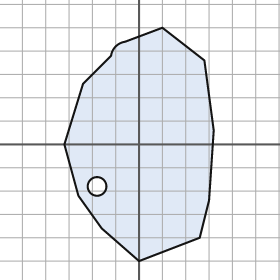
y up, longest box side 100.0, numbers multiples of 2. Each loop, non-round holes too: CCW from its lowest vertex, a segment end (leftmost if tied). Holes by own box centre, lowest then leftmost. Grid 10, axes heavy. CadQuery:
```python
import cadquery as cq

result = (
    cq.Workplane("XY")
    .moveTo(0.0, -50.0)
    .lineTo(26.0, -40.0)
    .lineTo(30.0, -24.0)
    .lineTo(32.0, 6.0)
    .lineTo(28.0, 36.0)
    .lineTo(10.0, 50.0)
    .lineTo(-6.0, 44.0)
    .threePointArc((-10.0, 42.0), (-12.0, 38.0))
    .lineTo(-24.0, 26.0)
    .lineTo(-32.0, 0.0)
    .lineTo(-26.0, -22.0)
    .lineTo(-16.0, -36.0)
    .close()
    .moveTo(-18.0, -18.0)
    .circle(4.0)
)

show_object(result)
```